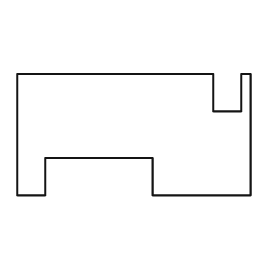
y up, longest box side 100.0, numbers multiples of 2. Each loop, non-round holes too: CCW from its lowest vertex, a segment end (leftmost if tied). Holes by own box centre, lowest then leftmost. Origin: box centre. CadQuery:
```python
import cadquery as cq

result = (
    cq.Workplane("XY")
    .moveTo(-50.0, -26.0)
    .lineTo(-38.0, -26.0)
    .lineTo(-38.0, -10.0)
    .lineTo(8.0, -10.0)
    .lineTo(8.0, -26.0)
    .lineTo(50.0, -26.0)
    .lineTo(50.0, 26.0)
    .lineTo(46.0, 26.0)
    .lineTo(46.0, 10.0)
    .lineTo(34.0, 10.0)
    .lineTo(34.0, 26.0)
    .lineTo(-50.0, 26.0)
    .close()
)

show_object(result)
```